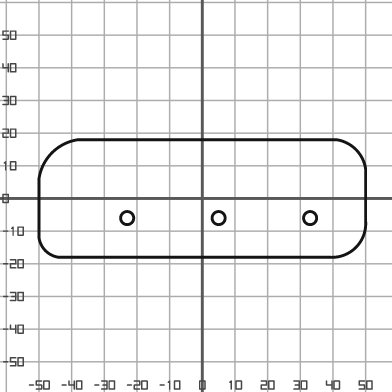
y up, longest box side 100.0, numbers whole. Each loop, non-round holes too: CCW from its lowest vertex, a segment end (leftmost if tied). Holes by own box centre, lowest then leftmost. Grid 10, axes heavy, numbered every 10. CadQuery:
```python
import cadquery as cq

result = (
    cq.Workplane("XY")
    .moveTo(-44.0, -18.0)
    .lineTo(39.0, -18.0)
    .threePointArc((47.0, -15.0), (50.0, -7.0))
    .lineTo(50.0, 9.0)
    .threePointArc((47.0, 15.0), (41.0, 18.0))
    .lineTo(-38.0, 18.0)
    .threePointArc((-46.0, 14.0), (-50.0, 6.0))
    .lineTo(-50.0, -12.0)
    .threePointArc((-48.0, -16.0), (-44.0, -18.0))
    .close()
    .moveTo(-23.0, -6.0)
    .circle(2.0)
    .moveTo(5.0, -6.0)
    .circle(2.0)
    .moveTo(33.0, -6.0)
    .circle(2.0)
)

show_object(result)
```